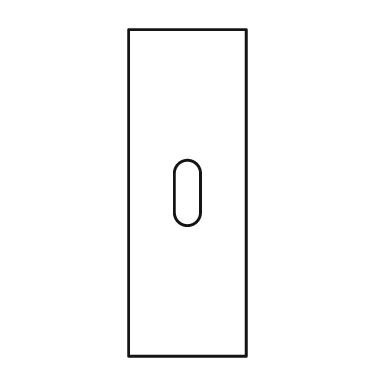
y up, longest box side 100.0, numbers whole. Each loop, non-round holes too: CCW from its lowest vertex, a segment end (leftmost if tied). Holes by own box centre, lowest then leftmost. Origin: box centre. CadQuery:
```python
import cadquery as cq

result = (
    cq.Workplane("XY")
    .moveTo(-18.0, -50.0)
    .lineTo(18.0, -50.0)
    .lineTo(18.0, 50.0)
    .lineTo(-18.0, 50.0)
    .close()
    .moveTo(-4.0, -6.0)
    .threePointArc((0.0, -10.0), (4.0, -6.0))
    .lineTo(4.0, 6.0)
    .threePointArc((0.0, 10.0), (-4.0, 6.0))
    .close()
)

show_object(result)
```